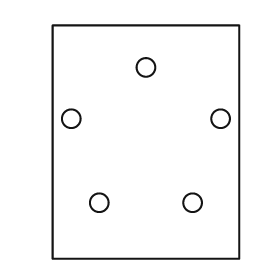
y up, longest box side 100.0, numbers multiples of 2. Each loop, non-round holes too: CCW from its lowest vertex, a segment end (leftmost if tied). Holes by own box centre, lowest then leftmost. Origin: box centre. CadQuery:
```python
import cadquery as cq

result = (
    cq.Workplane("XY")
    .moveTo(-40.0, -50.0)
    .lineTo(40.0, -50.0)
    .lineTo(40.0, 50.0)
    .lineTo(-40.0, 50.0)
    .close()
    .moveTo(-20.0, -26.0)
    .circle(4.0)
    .moveTo(20.0, -26.0)
    .circle(4.0)
    .moveTo(-32.0, 10.0)
    .circle(4.0)
    .moveTo(32.0, 10.0)
    .circle(4.0)
    .moveTo(0.0, 32.0)
    .circle(4.0)
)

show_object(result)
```